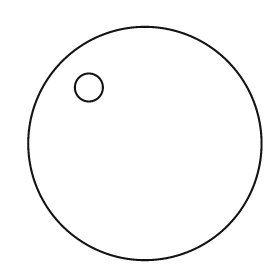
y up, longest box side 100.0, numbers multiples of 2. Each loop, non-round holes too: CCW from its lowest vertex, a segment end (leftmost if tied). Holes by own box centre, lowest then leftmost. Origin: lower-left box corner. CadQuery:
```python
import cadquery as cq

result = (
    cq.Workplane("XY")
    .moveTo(50.0, 50.0)
    .circle(50.0)
    .moveTo(26.0, 74.0)
    .circle(6.0)
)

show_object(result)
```